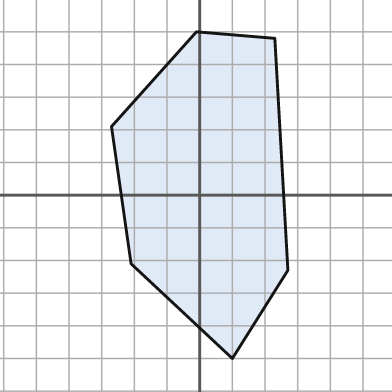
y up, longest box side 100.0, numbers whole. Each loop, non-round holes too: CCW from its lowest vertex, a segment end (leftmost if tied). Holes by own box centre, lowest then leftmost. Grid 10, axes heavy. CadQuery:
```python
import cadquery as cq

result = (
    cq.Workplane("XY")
    .moveTo(10.0, -50.0)
    .lineTo(27.0, -23.0)
    .lineTo(23.0, 48.0)
    .lineTo(-1.0, 50.0)
    .lineTo(-27.0, 21.0)
    .lineTo(-21.0, -21.0)
    .close()
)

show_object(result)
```